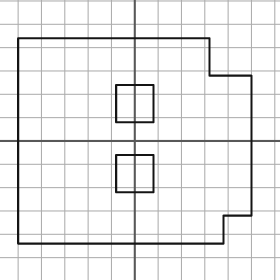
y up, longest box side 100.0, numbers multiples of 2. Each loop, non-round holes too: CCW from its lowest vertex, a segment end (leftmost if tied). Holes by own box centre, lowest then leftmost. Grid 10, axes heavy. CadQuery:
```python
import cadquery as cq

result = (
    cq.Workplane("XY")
    .moveTo(-50.0, -44.0)
    .lineTo(38.0, -44.0)
    .lineTo(38.0, -32.0)
    .lineTo(50.0, -32.0)
    .lineTo(50.0, 28.0)
    .lineTo(32.0, 28.0)
    .lineTo(32.0, 44.0)
    .lineTo(-50.0, 44.0)
    .close()
    .moveTo(-8.0, -22.0)
    .lineTo(8.0, -22.0)
    .lineTo(8.0, -6.0)
    .lineTo(-8.0, -6.0)
    .close()
    .moveTo(-8.0, 8.0)
    .lineTo(8.0, 8.0)
    .lineTo(8.0, 24.0)
    .lineTo(-8.0, 24.0)
    .close()
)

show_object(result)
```